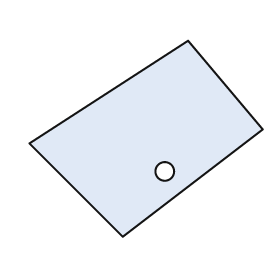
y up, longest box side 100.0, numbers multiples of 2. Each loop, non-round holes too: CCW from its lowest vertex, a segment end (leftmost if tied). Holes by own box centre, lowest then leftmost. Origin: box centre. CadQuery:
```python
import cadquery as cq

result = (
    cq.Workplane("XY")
    .moveTo(-10.0, -42.0)
    .lineTo(50.0, 4.0)
    .lineTo(18.0, 42.0)
    .lineTo(-50.0, -2.0)
    .close()
    .moveTo(8.0, -14.0)
    .circle(4.0)
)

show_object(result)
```